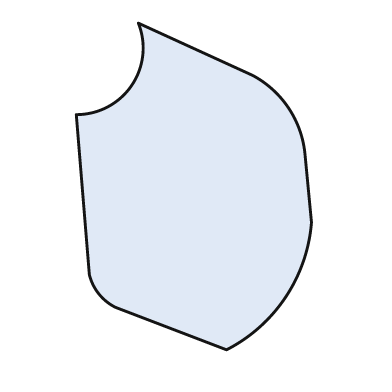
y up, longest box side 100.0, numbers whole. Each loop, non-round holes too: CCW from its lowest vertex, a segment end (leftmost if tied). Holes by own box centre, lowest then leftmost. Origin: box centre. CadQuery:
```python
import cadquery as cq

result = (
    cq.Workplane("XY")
    .moveTo(10.0, -50.0)
    .threePointArc((28.0, -34.0), (36.0, -11.0))
    .lineTo(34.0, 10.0)
    .threePointArc((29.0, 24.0), (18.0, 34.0))
    .lineTo(-17.0, 50.0)
    .threePointArc((-19.0, 31.0), (-36.0, 22.0))
    .lineTo(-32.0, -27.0)
    .threePointArc((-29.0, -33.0), (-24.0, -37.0))
    .close()
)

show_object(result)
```